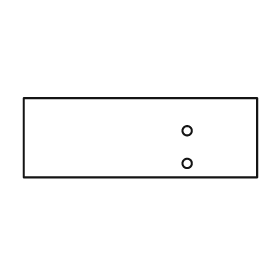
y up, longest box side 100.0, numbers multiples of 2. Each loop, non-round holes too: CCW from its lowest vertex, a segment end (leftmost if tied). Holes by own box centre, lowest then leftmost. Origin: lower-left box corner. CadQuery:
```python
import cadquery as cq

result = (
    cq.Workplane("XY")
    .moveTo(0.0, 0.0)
    .lineTo(100.0, 0.0)
    .lineTo(100.0, 34.0)
    .lineTo(0.0, 34.0)
    .close()
    .moveTo(70.0, 6.0)
    .circle(2.0)
    .moveTo(70.0, 20.0)
    .circle(2.0)
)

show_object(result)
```